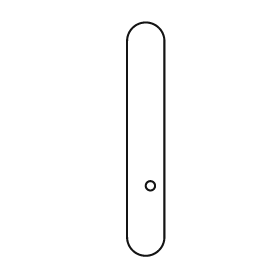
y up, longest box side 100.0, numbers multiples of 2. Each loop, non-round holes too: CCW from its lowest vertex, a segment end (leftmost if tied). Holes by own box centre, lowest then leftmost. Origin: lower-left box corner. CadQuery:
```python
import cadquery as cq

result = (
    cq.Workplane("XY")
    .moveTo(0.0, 8.0)
    .threePointArc((8.0, 0.0), (16.0, 8.0))
    .lineTo(16.0, 92.0)
    .threePointArc((8.0, 100.0), (0.0, 92.0))
    .close()
    .moveTo(10.0, 30.0)
    .circle(2.0)
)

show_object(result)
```